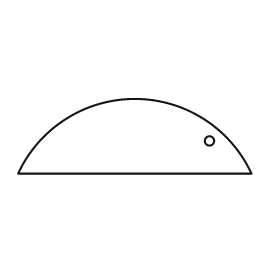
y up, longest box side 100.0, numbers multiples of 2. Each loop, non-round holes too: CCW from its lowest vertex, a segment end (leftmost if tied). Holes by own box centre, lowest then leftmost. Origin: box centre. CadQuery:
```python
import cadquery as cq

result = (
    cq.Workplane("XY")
    .moveTo(-50.0, -16.0)
    .lineTo(50.0, -16.0)
    .threePointArc((0.0, 16.0), (-50.0, -16.0))
    .close()
    .moveTo(32.0, -2.0)
    .circle(2.0)
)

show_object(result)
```